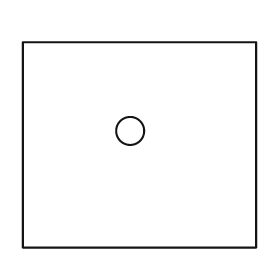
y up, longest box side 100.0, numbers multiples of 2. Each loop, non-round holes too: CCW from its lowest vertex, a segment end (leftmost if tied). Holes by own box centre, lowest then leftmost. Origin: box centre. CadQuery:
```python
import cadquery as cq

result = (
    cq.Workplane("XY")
    .moveTo(-50.0, -44.0)
    .lineTo(50.0, -44.0)
    .lineTo(50.0, 44.0)
    .lineTo(-50.0, 44.0)
    .close()
    .moveTo(-4.0, 6.0)
    .circle(6.0)
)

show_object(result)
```